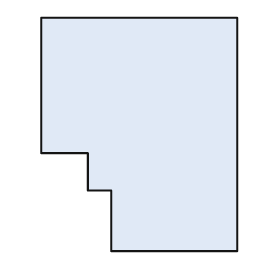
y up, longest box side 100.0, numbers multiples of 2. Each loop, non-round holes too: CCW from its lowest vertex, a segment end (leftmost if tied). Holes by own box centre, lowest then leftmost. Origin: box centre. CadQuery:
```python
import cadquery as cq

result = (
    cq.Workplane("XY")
    .moveTo(-12.0, -50.0)
    .lineTo(42.0, -50.0)
    .lineTo(42.0, 50.0)
    .lineTo(-42.0, 50.0)
    .lineTo(-42.0, -8.0)
    .lineTo(-22.0, -8.0)
    .lineTo(-22.0, -24.0)
    .lineTo(-12.0, -24.0)
    .close()
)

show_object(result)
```